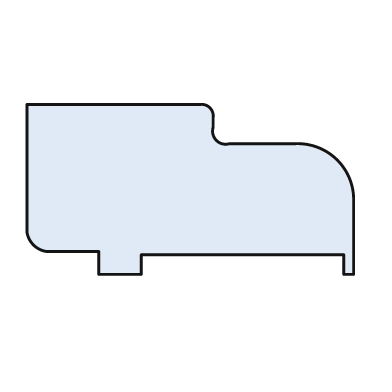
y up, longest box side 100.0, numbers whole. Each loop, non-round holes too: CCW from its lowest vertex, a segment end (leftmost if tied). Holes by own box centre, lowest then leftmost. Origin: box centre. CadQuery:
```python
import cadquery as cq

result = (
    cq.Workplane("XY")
    .moveTo(-28.0, -26.0)
    .lineTo(-15.0, -26.0)
    .lineTo(-15.0, -20.0)
    .lineTo(47.0, -20.0)
    .lineTo(47.0, -26.0)
    .lineTo(50.0, -26.0)
    .lineTo(50.0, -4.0)
    .threePointArc((45.0, 9.0), (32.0, 14.0))
    .lineTo(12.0, 14.0)
    .threePointArc((8.0, 15.0), (7.0, 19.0))
    .lineTo(7.0, 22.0)
    .threePointArc((6.0, 25.0), (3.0, 26.0))
    .lineTo(-50.0, 26.0)
    .lineTo(-50.0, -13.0)
    .threePointArc((-48.0, -17.0), (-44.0, -19.0))
    .lineTo(-28.0, -19.0)
    .close()
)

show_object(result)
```